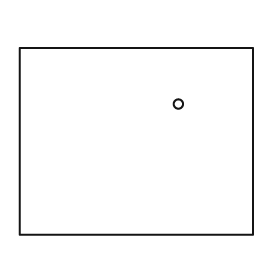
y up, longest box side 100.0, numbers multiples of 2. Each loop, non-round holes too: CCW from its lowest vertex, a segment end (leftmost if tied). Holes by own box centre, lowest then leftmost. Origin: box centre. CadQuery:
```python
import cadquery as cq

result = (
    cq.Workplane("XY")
    .moveTo(-50.0, -40.0)
    .lineTo(50.0, -40.0)
    .lineTo(50.0, 40.0)
    .lineTo(-50.0, 40.0)
    .close()
    .moveTo(18.0, 16.0)
    .circle(2.0)
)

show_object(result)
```